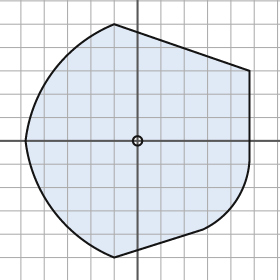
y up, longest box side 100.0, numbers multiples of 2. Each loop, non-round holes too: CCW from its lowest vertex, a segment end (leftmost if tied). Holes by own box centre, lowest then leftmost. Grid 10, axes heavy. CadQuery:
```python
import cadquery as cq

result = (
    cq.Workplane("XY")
    .moveTo(-10.0, -50.0)
    .lineTo(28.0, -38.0)
    .threePointArc((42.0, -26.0), (48.0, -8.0))
    .lineTo(48.0, 30.0)
    .lineTo(-10.0, 50.0)
    .threePointArc((-36.0, 30.0), (-48.0, 0.0))
    .threePointArc((-36.0, -30.0), (-10.0, -50.0))
    .close()
    .moveTo(0.0, 0.0)
    .circle(2.0)
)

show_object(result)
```